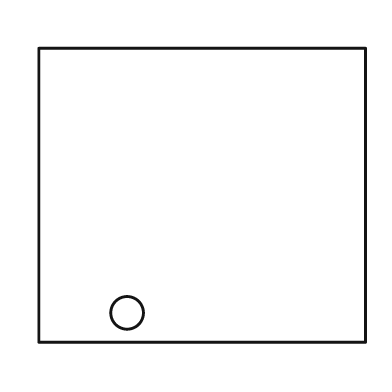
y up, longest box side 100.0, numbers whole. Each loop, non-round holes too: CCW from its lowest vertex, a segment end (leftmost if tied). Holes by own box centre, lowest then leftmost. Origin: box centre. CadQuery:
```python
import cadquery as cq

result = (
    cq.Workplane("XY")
    .moveTo(-50.0, -45.0)
    .lineTo(50.0, -45.0)
    .lineTo(50.0, 45.0)
    .lineTo(-50.0, 45.0)
    .close()
    .moveTo(-23.0, -36.0)
    .circle(5.0)
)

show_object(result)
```